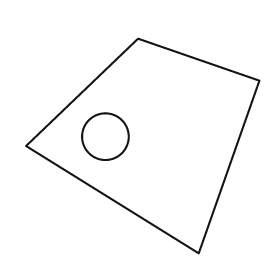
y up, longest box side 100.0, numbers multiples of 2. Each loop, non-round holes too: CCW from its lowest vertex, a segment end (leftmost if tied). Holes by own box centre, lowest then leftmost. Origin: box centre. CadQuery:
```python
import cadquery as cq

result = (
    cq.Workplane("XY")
    .moveTo(24.0, -46.0)
    .lineTo(50.0, 28.0)
    .lineTo(-2.0, 46.0)
    .lineTo(-50.0, 0.0)
    .close()
    .moveTo(-16.0, 4.0)
    .circle(10.0)
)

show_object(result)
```